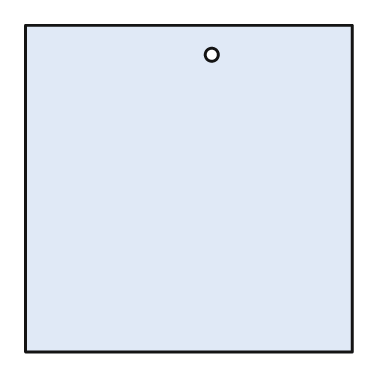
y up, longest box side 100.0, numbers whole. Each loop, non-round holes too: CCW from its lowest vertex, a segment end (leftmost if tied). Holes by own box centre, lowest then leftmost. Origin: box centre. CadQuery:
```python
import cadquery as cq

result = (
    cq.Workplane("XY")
    .moveTo(-50.0, -50.0)
    .lineTo(50.0, -50.0)
    .lineTo(50.0, 50.0)
    .lineTo(-50.0, 50.0)
    .close()
    .moveTo(7.0, 41.0)
    .circle(2.0)
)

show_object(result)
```